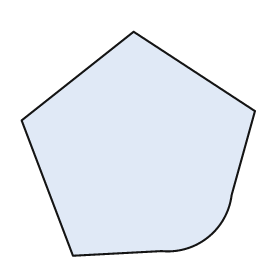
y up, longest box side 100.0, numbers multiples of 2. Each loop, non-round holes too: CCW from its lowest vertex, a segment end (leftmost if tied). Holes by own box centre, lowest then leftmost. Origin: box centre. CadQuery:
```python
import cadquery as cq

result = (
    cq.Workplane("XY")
    .moveTo(-28.0, -48.0)
    .lineTo(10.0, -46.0)
    .threePointArc((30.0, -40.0), (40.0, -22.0))
    .lineTo(50.0, 14.0)
    .lineTo(-2.0, 48.0)
    .lineTo(-50.0, 10.0)
    .close()
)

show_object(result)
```